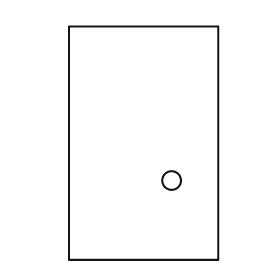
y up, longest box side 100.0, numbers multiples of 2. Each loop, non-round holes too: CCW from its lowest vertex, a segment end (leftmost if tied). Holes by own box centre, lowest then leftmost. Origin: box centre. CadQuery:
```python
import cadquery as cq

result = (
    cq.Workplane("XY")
    .moveTo(-32.0, -50.0)
    .lineTo(32.0, -50.0)
    .lineTo(32.0, 50.0)
    .lineTo(-32.0, 50.0)
    .close()
    .moveTo(12.0, -16.0)
    .circle(4.0)
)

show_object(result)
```